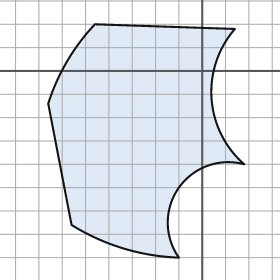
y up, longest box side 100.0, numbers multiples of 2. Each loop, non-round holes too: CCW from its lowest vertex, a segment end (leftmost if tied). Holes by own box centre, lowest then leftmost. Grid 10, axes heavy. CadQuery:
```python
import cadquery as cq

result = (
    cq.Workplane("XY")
    .moveTo(-10.0, -80.0)
    .threePointArc((-10.0, -50.0), (18.0, -40.0))
    .threePointArc((4.0, -12.0), (14.0, 18.0))
    .lineTo(-46.0, 20.0)
    .threePointArc((-58.0, 4.0), (-66.0, -14.0))
    .lineTo(-56.0, -66.0)
    .threePointArc((-34.0, -76.0), (-10.0, -80.0))
    .close()
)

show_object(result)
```